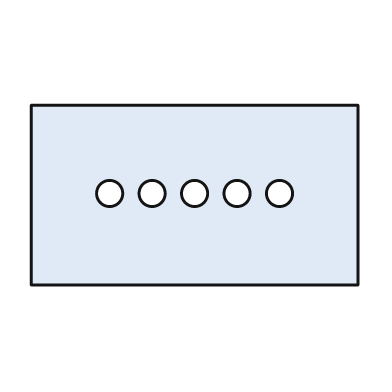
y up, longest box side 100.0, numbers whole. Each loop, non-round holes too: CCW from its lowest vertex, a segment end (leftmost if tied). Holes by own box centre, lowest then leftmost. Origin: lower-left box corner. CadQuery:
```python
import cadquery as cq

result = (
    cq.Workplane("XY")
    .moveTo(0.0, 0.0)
    .lineTo(100.0, 0.0)
    .lineTo(100.0, 55.0)
    .lineTo(0.0, 55.0)
    .close()
    .moveTo(24.0, 28.0)
    .circle(4.0)
    .moveTo(37.0, 28.0)
    .circle(4.0)
    .moveTo(50.0, 28.0)
    .circle(4.0)
    .moveTo(63.0, 28.0)
    .circle(4.0)
    .moveTo(76.0, 28.0)
    .circle(4.0)
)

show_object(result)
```